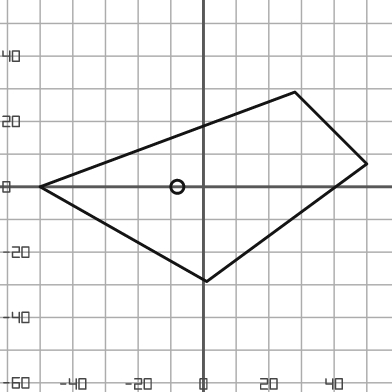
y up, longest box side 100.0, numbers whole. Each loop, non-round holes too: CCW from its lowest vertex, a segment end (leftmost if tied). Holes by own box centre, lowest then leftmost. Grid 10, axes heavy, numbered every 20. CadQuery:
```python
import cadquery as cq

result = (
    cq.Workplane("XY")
    .moveTo(1.0, -29.0)
    .lineTo(50.0, 7.0)
    .lineTo(28.0, 29.0)
    .lineTo(-50.0, 0.0)
    .close()
    .moveTo(-8.0, 0.0)
    .circle(2.0)
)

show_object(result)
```